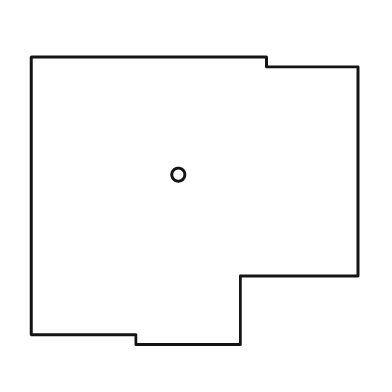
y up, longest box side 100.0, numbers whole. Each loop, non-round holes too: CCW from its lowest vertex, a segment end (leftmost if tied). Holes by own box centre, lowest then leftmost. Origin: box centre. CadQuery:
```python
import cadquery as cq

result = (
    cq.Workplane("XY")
    .moveTo(-18.0, -44.0)
    .lineTo(14.0, -44.0)
    .lineTo(14.0, -23.0)
    .lineTo(50.0, -23.0)
    .lineTo(50.0, 41.0)
    .lineTo(22.0, 41.0)
    .lineTo(22.0, 44.0)
    .lineTo(-50.0, 44.0)
    .lineTo(-50.0, -41.0)
    .lineTo(-18.0, -41.0)
    .close()
    .moveTo(-5.0, 8.0)
    .circle(2.0)
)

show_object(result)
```